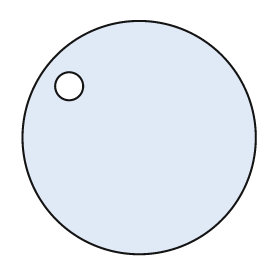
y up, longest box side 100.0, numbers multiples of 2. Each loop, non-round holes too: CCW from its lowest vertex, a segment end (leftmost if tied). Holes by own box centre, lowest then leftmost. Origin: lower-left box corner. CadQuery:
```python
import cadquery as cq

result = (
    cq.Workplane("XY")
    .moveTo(50.0, 50.0)
    .circle(50.0)
    .moveTo(20.0, 72.0)
    .circle(6.0)
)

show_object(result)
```